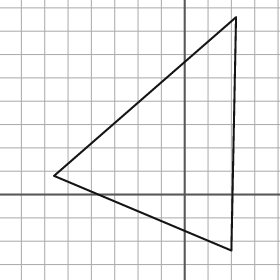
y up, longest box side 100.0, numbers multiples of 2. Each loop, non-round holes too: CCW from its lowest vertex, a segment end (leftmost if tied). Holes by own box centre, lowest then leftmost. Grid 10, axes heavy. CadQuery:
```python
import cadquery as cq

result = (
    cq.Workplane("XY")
    .moveTo(20.0, -24.0)
    .lineTo(22.0, 76.0)
    .lineTo(-56.0, 8.0)
    .close()
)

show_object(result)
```